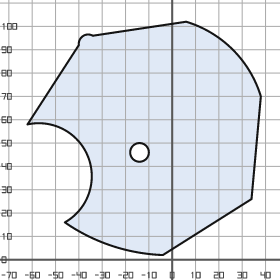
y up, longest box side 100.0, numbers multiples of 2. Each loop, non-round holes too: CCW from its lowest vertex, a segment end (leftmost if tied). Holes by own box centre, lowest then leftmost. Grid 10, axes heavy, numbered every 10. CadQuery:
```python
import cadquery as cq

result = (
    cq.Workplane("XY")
    .moveTo(-4.0, 2.0)
    .lineTo(34.0, 26.0)
    .lineTo(38.0, 70.0)
    .threePointArc((26.0, 90.0), (6.0, 102.0))
    .lineTo(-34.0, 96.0)
    .threePointArc((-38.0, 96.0), (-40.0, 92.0))
    .lineTo(-62.0, 58.0)
    .threePointArc((-36.0, 44.0), (-46.0, 16.0))
    .threePointArc((-26.0, 6.0), (-4.0, 2.0))
    .close()
    .moveTo(-14.0, 46.0)
    .circle(4.0)
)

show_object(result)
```